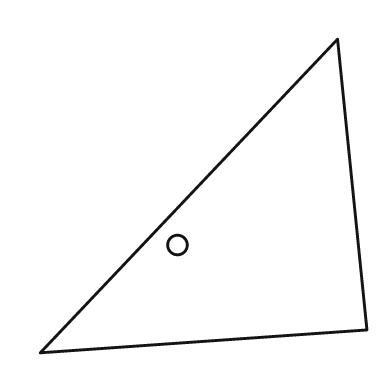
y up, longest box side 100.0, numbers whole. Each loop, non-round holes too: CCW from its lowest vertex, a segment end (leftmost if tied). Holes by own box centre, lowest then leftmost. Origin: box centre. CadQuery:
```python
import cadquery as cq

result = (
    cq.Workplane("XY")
    .moveTo(-50.0, -48.0)
    .lineTo(50.0, -41.0)
    .lineTo(41.0, 48.0)
    .close()
    .moveTo(-8.0, -15.0)
    .circle(3.0)
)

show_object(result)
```